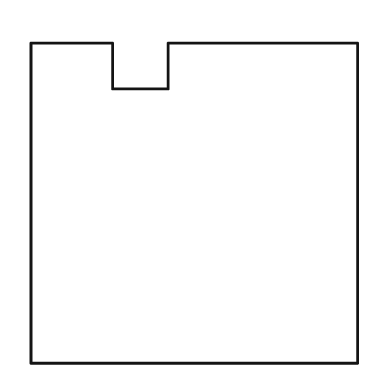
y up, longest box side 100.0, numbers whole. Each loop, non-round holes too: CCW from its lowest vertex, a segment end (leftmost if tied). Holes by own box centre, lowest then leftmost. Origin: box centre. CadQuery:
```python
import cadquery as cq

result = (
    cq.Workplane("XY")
    .moveTo(-50.0, -49.0)
    .lineTo(50.0, -49.0)
    .lineTo(50.0, 49.0)
    .lineTo(-8.0, 49.0)
    .lineTo(-8.0, 35.0)
    .lineTo(-25.0, 35.0)
    .lineTo(-25.0, 49.0)
    .lineTo(-50.0, 49.0)
    .close()
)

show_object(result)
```